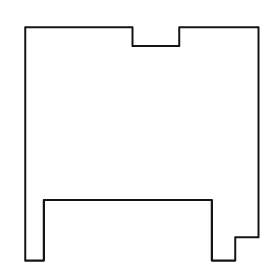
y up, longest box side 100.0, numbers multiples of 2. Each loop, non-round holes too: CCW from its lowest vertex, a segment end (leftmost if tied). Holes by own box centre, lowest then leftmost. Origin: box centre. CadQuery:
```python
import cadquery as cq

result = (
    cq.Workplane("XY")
    .moveTo(-50.0, -50.0)
    .lineTo(-42.0, -50.0)
    .lineTo(-42.0, -24.0)
    .lineTo(30.0, -24.0)
    .lineTo(30.0, -50.0)
    .lineTo(40.0, -50.0)
    .lineTo(40.0, -40.0)
    .lineTo(50.0, -40.0)
    .lineTo(50.0, 50.0)
    .lineTo(16.0, 50.0)
    .lineTo(16.0, 42.0)
    .lineTo(-4.0, 42.0)
    .lineTo(-4.0, 50.0)
    .lineTo(-50.0, 50.0)
    .close()
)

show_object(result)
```